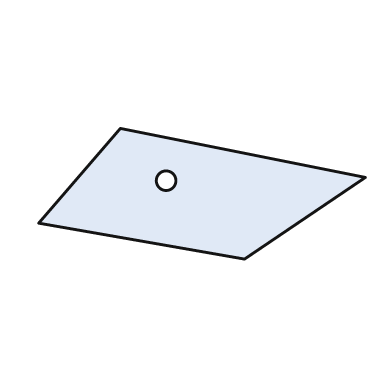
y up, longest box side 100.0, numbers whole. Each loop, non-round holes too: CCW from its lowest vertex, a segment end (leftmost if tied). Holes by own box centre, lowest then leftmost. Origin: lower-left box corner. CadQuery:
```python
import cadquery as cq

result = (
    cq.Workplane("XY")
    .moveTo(63.0, 0.0)
    .lineTo(100.0, 25.0)
    .lineTo(25.0, 40.0)
    .lineTo(0.0, 11.0)
    .close()
    .moveTo(39.0, 24.0)
    .circle(3.0)
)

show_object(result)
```